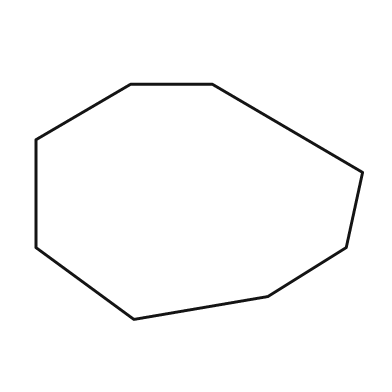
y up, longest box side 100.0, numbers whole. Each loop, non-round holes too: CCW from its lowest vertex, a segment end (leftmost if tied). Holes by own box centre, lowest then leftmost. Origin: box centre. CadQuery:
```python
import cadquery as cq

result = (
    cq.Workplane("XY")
    .moveTo(-20.0, -36.0)
    .lineTo(21.0, -29.0)
    .lineTo(45.0, -14.0)
    .lineTo(50.0, 9.0)
    .lineTo(4.0, 36.0)
    .lineTo(-21.0, 36.0)
    .lineTo(-50.0, 19.0)
    .lineTo(-50.0, -14.0)
    .close()
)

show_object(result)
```